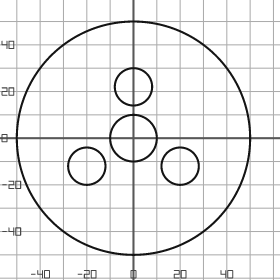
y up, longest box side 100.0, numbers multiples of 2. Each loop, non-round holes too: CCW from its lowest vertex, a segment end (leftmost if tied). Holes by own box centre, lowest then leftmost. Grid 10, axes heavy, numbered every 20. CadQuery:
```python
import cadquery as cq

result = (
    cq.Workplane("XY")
    .moveTo(0.0, 0.0)
    .circle(50.0)
    .moveTo(-20.0, -12.0)
    .circle(8.0)
    .moveTo(20.0, -12.0)
    .circle(8.0)
    .moveTo(0.0, 0.0)
    .circle(10.0)
    .moveTo(0.0, 22.0)
    .circle(8.0)
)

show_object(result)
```